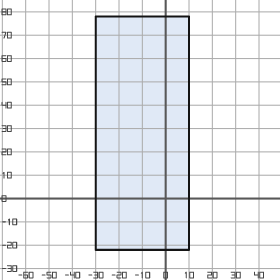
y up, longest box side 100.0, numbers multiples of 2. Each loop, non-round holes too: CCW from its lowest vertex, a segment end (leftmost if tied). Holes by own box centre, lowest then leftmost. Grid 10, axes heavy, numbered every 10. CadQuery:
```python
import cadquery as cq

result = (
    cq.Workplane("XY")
    .moveTo(-30.0, -22.0)
    .lineTo(10.0, -22.0)
    .lineTo(10.0, 78.0)
    .lineTo(-30.0, 78.0)
    .close()
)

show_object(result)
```